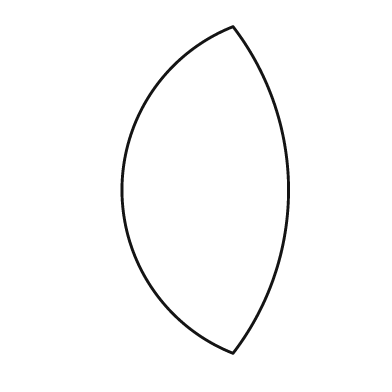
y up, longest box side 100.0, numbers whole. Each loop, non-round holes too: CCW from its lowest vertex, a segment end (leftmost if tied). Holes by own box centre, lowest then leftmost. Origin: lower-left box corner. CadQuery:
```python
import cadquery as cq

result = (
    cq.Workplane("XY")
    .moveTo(34.0, 0.0)
    .threePointArc((51.0, 50.0), (34.0, 100.0))
    .threePointArc((0.0, 50.0), (34.0, 0.0))
    .close()
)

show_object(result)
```